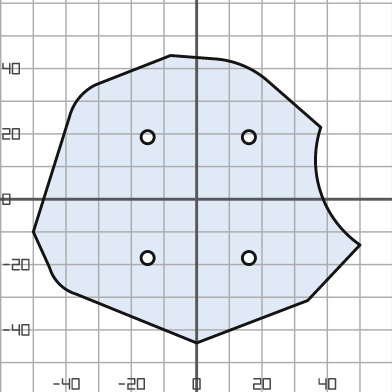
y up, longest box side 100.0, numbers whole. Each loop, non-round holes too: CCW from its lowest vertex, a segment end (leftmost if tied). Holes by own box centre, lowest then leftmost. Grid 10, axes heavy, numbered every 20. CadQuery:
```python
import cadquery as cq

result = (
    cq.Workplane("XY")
    .moveTo(0.0, -44.0)
    .lineTo(34.0, -31.0)
    .lineTo(50.0, -14.0)
    .threePointArc((38.0, 2.0), (38.0, 22.0))
    .lineTo(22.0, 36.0)
    .threePointArc((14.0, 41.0), (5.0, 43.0))
    .lineTo(-8.0, 44.0)
    .lineTo(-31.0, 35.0)
    .threePointArc((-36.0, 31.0), (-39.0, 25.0))
    .lineTo(-50.0, -10.0)
    .lineTo(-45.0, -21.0)
    .threePointArc((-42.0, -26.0), (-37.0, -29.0))
    .close()
    .moveTo(-15.0, -18.0)
    .circle(2.0)
    .moveTo(16.0, -18.0)
    .circle(2.0)
    .moveTo(-15.0, 19.0)
    .circle(2.0)
    .moveTo(16.0, 19.0)
    .circle(2.0)
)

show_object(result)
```